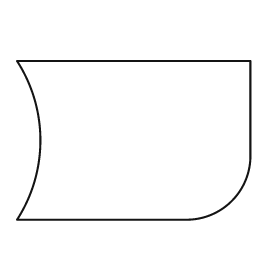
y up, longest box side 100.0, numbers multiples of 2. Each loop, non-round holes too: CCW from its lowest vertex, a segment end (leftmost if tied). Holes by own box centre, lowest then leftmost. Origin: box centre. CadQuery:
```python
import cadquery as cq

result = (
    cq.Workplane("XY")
    .moveTo(-50.0, -34.0)
    .lineTo(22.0, -34.0)
    .threePointArc((42.0, -26.0), (50.0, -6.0))
    .lineTo(50.0, 34.0)
    .lineTo(-50.0, 34.0)
    .threePointArc((-40.0, 0.0), (-50.0, -34.0))
    .close()
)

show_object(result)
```